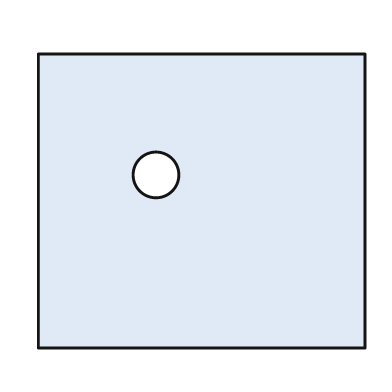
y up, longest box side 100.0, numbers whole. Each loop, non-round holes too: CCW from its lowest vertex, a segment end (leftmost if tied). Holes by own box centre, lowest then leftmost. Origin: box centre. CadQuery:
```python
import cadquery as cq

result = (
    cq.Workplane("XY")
    .moveTo(-50.0, -45.0)
    .lineTo(50.0, -45.0)
    .lineTo(50.0, 45.0)
    .lineTo(-50.0, 45.0)
    .close()
    .moveTo(-14.0, 8.0)
    .circle(7.0)
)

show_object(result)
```